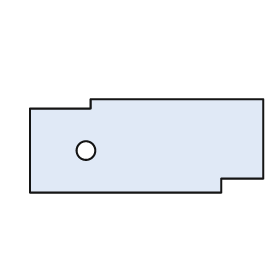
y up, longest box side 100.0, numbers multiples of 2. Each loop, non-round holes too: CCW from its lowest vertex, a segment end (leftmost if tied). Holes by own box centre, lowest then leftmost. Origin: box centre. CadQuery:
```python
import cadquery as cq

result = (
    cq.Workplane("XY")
    .moveTo(-50.0, -20.0)
    .lineTo(32.0, -20.0)
    .lineTo(32.0, -14.0)
    .lineTo(50.0, -14.0)
    .lineTo(50.0, 20.0)
    .lineTo(-24.0, 20.0)
    .lineTo(-24.0, 16.0)
    .lineTo(-50.0, 16.0)
    .close()
    .moveTo(-26.0, -2.0)
    .circle(4.0)
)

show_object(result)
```